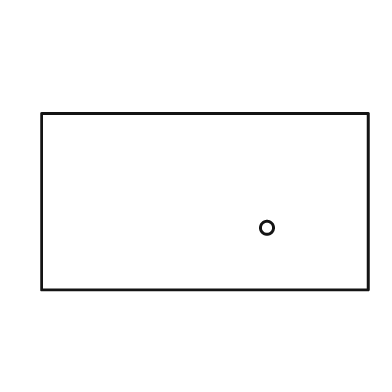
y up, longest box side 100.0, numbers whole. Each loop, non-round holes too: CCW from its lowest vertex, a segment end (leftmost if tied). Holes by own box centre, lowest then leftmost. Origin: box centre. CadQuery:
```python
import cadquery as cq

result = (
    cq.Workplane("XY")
    .moveTo(-50.0, -27.0)
    .lineTo(50.0, -27.0)
    .lineTo(50.0, 27.0)
    .lineTo(-50.0, 27.0)
    .close()
    .moveTo(19.0, -8.0)
    .circle(2.0)
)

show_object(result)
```